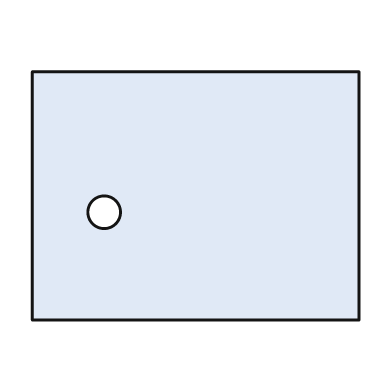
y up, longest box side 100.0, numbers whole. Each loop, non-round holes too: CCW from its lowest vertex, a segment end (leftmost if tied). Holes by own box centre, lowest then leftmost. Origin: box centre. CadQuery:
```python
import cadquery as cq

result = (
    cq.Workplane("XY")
    .moveTo(-50.0, -38.0)
    .lineTo(50.0, -38.0)
    .lineTo(50.0, 38.0)
    .lineTo(-50.0, 38.0)
    .close()
    .moveTo(-28.0, -5.0)
    .circle(5.0)
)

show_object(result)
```